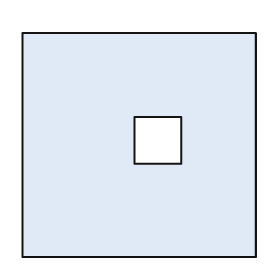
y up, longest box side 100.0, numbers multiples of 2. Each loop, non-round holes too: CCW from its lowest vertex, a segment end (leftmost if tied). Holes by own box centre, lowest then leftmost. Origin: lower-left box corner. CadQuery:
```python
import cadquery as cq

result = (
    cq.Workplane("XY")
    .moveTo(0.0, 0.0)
    .lineTo(100.0, 0.0)
    .lineTo(100.0, 96.0)
    .lineTo(0.0, 96.0)
    .close()
    .moveTo(48.0, 40.0)
    .lineTo(68.0, 40.0)
    .lineTo(68.0, 60.0)
    .lineTo(48.0, 60.0)
    .close()
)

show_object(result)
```